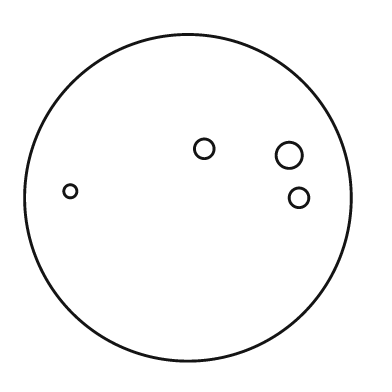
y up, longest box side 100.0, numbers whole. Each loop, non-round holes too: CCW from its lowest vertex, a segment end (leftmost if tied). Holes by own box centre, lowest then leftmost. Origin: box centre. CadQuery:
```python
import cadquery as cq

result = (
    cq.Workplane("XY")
    .moveTo(0.0, 0.0)
    .circle(50.0)
    .moveTo(34.0, 0.0)
    .circle(3.0)
    .moveTo(-36.0, 2.0)
    .circle(2.0)
    .moveTo(31.0, 13.0)
    .circle(4.0)
    .moveTo(5.0, 15.0)
    .circle(3.0)
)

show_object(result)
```